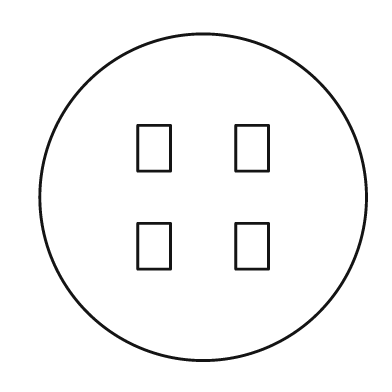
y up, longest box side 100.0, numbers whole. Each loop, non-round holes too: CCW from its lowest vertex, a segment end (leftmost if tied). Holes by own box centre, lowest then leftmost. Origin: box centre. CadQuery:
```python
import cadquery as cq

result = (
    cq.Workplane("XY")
    .moveTo(0.0, 0.0)
    .circle(50.0)
    .moveTo(-20.0, -22.0)
    .lineTo(-10.0, -22.0)
    .lineTo(-10.0, -8.0)
    .lineTo(-20.0, -8.0)
    .close()
    .moveTo(10.0, -22.0)
    .lineTo(20.0, -22.0)
    .lineTo(20.0, -8.0)
    .lineTo(10.0, -8.0)
    .close()
    .moveTo(-20.0, 8.0)
    .lineTo(-10.0, 8.0)
    .lineTo(-10.0, 22.0)
    .lineTo(-20.0, 22.0)
    .close()
    .moveTo(10.0, 8.0)
    .lineTo(20.0, 8.0)
    .lineTo(20.0, 22.0)
    .lineTo(10.0, 22.0)
    .close()
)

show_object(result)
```